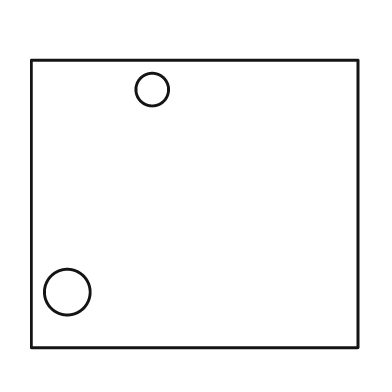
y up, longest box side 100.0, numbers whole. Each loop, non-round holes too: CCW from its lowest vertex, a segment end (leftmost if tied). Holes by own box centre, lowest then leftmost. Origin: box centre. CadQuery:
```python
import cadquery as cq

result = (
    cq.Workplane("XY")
    .moveTo(-50.0, -44.0)
    .lineTo(50.0, -44.0)
    .lineTo(50.0, 44.0)
    .lineTo(-50.0, 44.0)
    .close()
    .moveTo(-39.0, -27.0)
    .circle(7.0)
    .moveTo(-13.0, 35.0)
    .circle(5.0)
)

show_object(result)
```